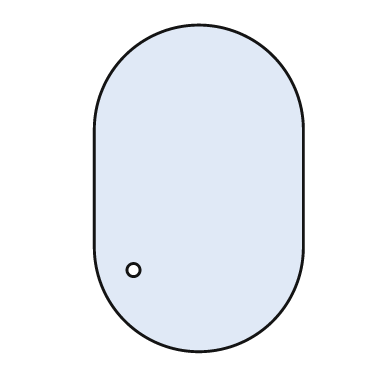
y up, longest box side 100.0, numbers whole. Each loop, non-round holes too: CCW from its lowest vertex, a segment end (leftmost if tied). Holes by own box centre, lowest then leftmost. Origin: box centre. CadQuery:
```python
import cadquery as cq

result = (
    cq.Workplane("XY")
    .moveTo(-32.0, -18.0)
    .threePointArc((0.0, -50.0), (32.0, -18.0))
    .lineTo(32.0, 18.0)
    .threePointArc((0.0, 50.0), (-32.0, 18.0))
    .close()
    .moveTo(-20.0, -25.0)
    .circle(2.0)
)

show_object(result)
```